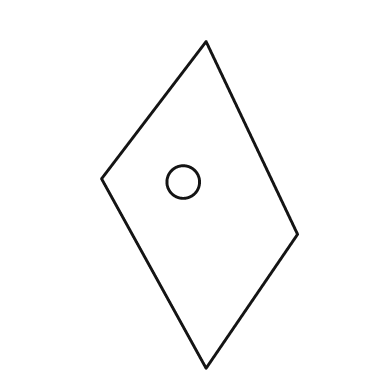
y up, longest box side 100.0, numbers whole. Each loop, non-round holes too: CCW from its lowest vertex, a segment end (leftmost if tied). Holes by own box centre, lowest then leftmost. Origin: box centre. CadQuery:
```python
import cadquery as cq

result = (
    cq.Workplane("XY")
    .moveTo(2.0, -50.0)
    .lineTo(30.0, -9.0)
    .lineTo(2.0, 50.0)
    .lineTo(-30.0, 8.0)
    .close()
    .moveTo(-5.0, 7.0)
    .circle(5.0)
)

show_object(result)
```